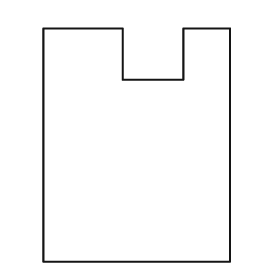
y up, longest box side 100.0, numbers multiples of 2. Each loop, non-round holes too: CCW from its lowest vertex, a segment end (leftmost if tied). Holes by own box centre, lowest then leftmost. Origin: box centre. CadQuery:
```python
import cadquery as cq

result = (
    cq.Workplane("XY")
    .moveTo(-40.0, -50.0)
    .lineTo(40.0, -50.0)
    .lineTo(40.0, 50.0)
    .lineTo(20.0, 50.0)
    .lineTo(20.0, 28.0)
    .lineTo(-6.0, 28.0)
    .lineTo(-6.0, 50.0)
    .lineTo(-40.0, 50.0)
    .close()
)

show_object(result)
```